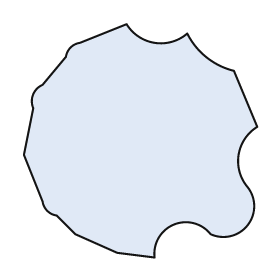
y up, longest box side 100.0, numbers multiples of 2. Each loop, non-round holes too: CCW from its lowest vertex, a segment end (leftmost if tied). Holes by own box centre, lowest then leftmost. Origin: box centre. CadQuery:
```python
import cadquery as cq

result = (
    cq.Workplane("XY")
    .moveTo(6.0, -50.0)
    .threePointArc((14.0, -36.0), (30.0, -40.0))
    .threePointArc((46.0, -36.0), (46.0, -20.0))
    .threePointArc((42.0, -6.0), (50.0, 6.0))
    .lineTo(40.0, 30.0)
    .threePointArc((28.0, 36.0), (20.0, 46.0))
    .threePointArc((6.0, 42.0), (-6.0, 50.0))
    .lineTo(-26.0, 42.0)
    .threePointArc((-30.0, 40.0), (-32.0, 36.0))
    .lineTo(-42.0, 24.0)
    .threePointArc((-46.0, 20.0), (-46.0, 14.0))
    .lineTo(-50.0, -6.0)
    .lineTo(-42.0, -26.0)
    .threePointArc((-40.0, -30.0), (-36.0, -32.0))
    .lineTo(-28.0, -40.0)
    .lineTo(-10.0, -48.0)
    .close()
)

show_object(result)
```